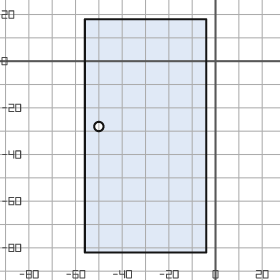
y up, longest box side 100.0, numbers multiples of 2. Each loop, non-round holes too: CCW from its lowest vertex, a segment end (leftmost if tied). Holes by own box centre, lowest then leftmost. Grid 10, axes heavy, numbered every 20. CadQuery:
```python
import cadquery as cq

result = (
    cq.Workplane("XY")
    .moveTo(-56.0, -82.0)
    .lineTo(-4.0, -82.0)
    .lineTo(-4.0, 18.0)
    .lineTo(-56.0, 18.0)
    .close()
    .moveTo(-50.0, -28.0)
    .circle(2.0)
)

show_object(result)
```